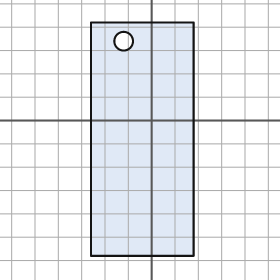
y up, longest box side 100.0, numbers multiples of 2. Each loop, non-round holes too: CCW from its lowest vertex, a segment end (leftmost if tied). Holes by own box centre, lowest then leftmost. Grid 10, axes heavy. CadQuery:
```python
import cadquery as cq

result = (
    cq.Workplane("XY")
    .moveTo(-26.0, -58.0)
    .lineTo(18.0, -58.0)
    .lineTo(18.0, 42.0)
    .lineTo(-26.0, 42.0)
    .close()
    .moveTo(-12.0, 34.0)
    .circle(4.0)
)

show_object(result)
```